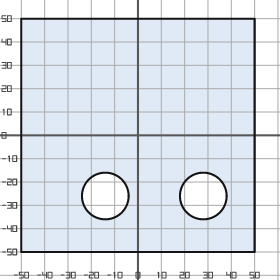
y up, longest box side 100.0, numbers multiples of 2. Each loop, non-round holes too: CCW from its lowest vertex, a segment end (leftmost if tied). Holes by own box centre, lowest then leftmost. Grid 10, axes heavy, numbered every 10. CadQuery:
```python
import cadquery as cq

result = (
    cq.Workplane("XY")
    .moveTo(-50.0, -50.0)
    .lineTo(50.0, -50.0)
    .lineTo(50.0, 50.0)
    .lineTo(-50.0, 50.0)
    .close()
    .moveTo(-14.0, -26.0)
    .circle(10.0)
    .moveTo(28.0, -26.0)
    .circle(10.0)
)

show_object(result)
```